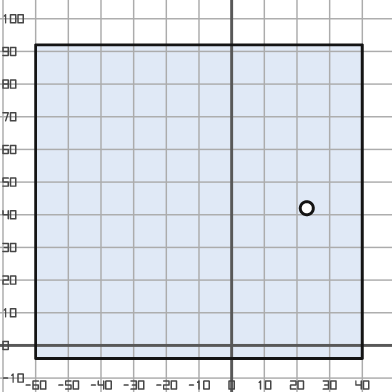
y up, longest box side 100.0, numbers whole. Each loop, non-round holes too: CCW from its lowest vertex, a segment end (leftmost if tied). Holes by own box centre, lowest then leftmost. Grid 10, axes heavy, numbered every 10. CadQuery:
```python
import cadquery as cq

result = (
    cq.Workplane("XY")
    .moveTo(-60.0, -4.0)
    .lineTo(40.0, -4.0)
    .lineTo(40.0, 92.0)
    .lineTo(-60.0, 92.0)
    .close()
    .moveTo(23.0, 42.0)
    .circle(2.0)
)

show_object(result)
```